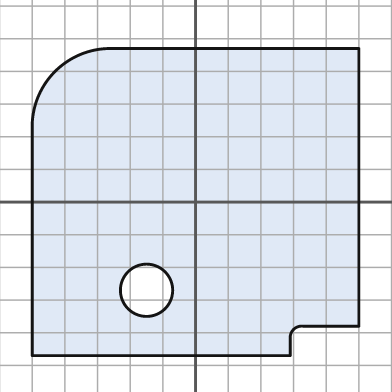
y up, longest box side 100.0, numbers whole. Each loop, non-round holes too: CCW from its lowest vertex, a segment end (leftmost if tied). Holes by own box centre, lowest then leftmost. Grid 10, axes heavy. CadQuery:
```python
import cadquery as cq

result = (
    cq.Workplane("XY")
    .moveTo(-50.0, -47.0)
    .lineTo(29.0, -47.0)
    .lineTo(29.0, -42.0)
    .threePointArc((30.0, -39.0), (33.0, -38.0))
    .lineTo(50.0, -38.0)
    .lineTo(50.0, 47.0)
    .lineTo(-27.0, 47.0)
    .threePointArc((-43.0, 40.0), (-50.0, 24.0))
    .close()
    .moveTo(-15.0, -27.0)
    .circle(8.0)
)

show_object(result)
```